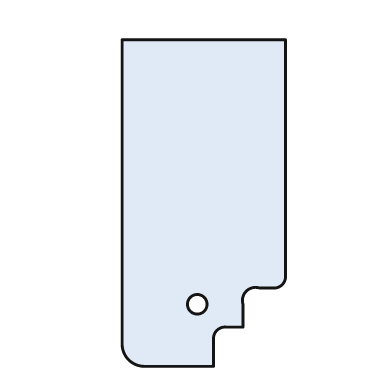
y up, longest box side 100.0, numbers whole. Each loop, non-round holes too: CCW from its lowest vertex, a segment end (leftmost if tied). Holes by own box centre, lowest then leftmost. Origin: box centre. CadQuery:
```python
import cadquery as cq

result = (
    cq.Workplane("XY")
    .moveTo(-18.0, -50.0)
    .lineTo(3.0, -50.0)
    .lineTo(3.0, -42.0)
    .threePointArc((4.0, -39.0), (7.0, -38.0))
    .lineTo(12.0, -38.0)
    .lineTo(12.0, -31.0)
    .threePointArc((13.0, -27.0), (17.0, -26.0))
    .lineTo(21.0, -26.0)
    .threePointArc((24.0, -25.0), (25.0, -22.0))
    .lineTo(25.0, 50.0)
    .lineTo(-25.0, 50.0)
    .lineTo(-25.0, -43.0)
    .threePointArc((-23.0, -48.0), (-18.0, -50.0))
    .close()
    .moveTo(-2.0, -31.0)
    .circle(3.0)
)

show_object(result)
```